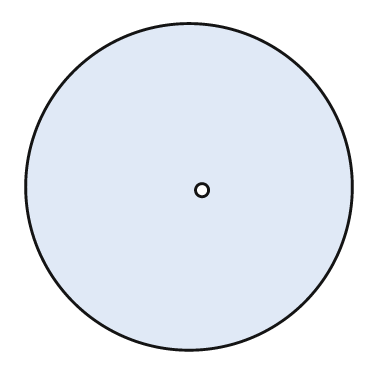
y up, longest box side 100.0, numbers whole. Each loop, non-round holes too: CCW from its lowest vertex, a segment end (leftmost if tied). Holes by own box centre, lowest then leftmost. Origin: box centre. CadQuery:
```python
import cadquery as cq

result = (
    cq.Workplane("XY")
    .moveTo(0.0, 0.0)
    .circle(50.0)
    .moveTo(4.0, -1.0)
    .circle(2.0)
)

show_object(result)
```